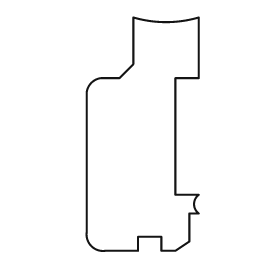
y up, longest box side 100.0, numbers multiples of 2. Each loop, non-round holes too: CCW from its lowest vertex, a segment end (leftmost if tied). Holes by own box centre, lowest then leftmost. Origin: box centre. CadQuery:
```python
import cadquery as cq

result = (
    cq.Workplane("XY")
    .moveTo(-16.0, -50.0)
    .lineTo(-2.0, -50.0)
    .lineTo(-2.0, -44.0)
    .lineTo(8.0, -44.0)
    .lineTo(8.0, -50.0)
    .lineTo(14.0, -50.0)
    .lineTo(20.0, -46.0)
    .lineTo(20.0, -34.0)
    .lineTo(24.0, -34.0)
    .threePointArc((22.0, -30.0), (24.0, -26.0))
    .lineTo(14.0, -26.0)
    .lineTo(14.0, 24.0)
    .lineTo(24.0, 24.0)
    .lineTo(24.0, 50.0)
    .threePointArc((10.0, 48.0), (-4.0, 50.0))
    .lineTo(-4.0, 30.0)
    .lineTo(-10.0, 24.0)
    .lineTo(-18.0, 24.0)
    .threePointArc((-22.0, 22.0), (-24.0, 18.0))
    .lineTo(-24.0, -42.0)
    .threePointArc((-22.0, -48.0), (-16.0, -50.0))
    .close()
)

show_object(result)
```